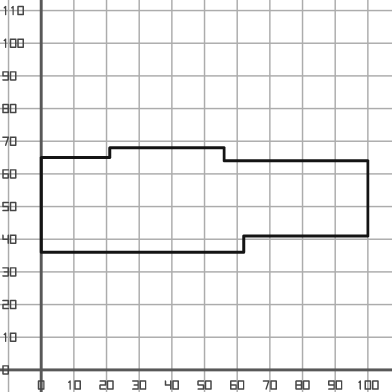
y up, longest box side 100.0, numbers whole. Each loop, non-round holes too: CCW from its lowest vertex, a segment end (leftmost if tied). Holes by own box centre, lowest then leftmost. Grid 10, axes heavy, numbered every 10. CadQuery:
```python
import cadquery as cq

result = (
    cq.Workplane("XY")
    .moveTo(0.0, 36.0)
    .lineTo(62.0, 36.0)
    .lineTo(62.0, 41.0)
    .lineTo(100.0, 41.0)
    .lineTo(100.0, 64.0)
    .lineTo(56.0, 64.0)
    .lineTo(56.0, 68.0)
    .lineTo(21.0, 68.0)
    .lineTo(21.0, 65.0)
    .lineTo(0.0, 65.0)
    .close()
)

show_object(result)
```